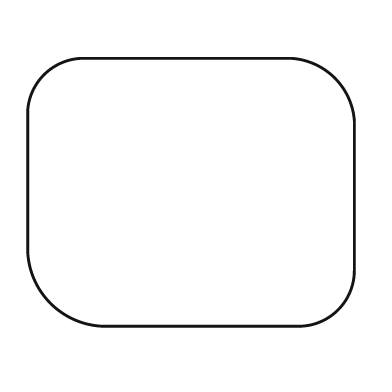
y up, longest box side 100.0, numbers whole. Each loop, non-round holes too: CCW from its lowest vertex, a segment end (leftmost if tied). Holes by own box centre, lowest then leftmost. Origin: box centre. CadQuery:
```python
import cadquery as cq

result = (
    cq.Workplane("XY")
    .moveTo(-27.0, -41.0)
    .lineTo(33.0, -41.0)
    .threePointArc((45.0, -36.0), (50.0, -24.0))
    .lineTo(50.0, 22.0)
    .threePointArc((44.0, 35.0), (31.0, 41.0))
    .lineTo(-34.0, 41.0)
    .threePointArc((-45.0, 36.0), (-50.0, 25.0))
    .lineTo(-50.0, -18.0)
    .threePointArc((-43.0, -34.0), (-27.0, -41.0))
    .close()
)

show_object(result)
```